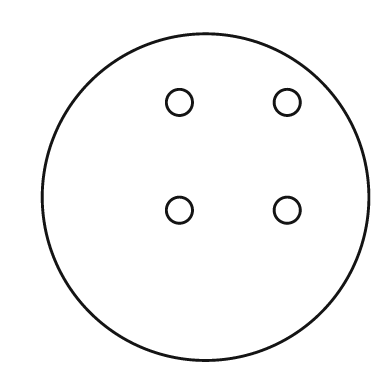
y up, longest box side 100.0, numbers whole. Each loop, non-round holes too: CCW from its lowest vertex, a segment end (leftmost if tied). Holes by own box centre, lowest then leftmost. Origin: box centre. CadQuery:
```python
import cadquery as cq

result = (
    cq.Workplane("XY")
    .moveTo(0.0, 0.0)
    .circle(50.0)
    .moveTo(-8.0, -4.0)
    .circle(4.0)
    .moveTo(25.0, -4.0)
    .circle(4.0)
    .moveTo(-8.0, 29.0)
    .circle(4.0)
    .moveTo(25.0, 29.0)
    .circle(4.0)
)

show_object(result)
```